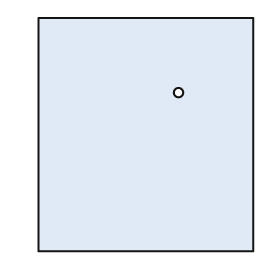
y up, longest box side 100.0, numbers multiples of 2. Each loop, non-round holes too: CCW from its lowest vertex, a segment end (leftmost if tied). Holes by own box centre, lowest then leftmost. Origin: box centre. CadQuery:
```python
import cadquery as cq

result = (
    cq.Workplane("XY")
    .moveTo(-46.0, -50.0)
    .lineTo(46.0, -50.0)
    .lineTo(46.0, 50.0)
    .lineTo(-46.0, 50.0)
    .close()
    .moveTo(14.0, 18.0)
    .circle(2.0)
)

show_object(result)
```